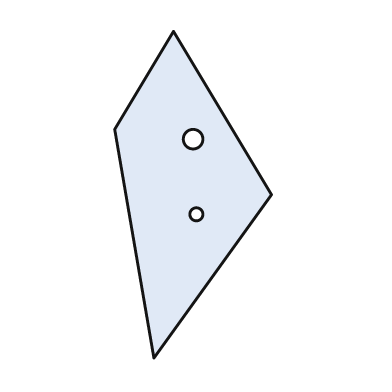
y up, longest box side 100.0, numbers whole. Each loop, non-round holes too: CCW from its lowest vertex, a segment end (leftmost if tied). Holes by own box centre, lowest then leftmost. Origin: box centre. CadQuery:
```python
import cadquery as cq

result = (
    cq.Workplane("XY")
    .moveTo(-12.0, -50.0)
    .lineTo(24.0, 0.0)
    .lineTo(-6.0, 50.0)
    .lineTo(-24.0, 20.0)
    .close()
    .moveTo(1.0, -6.0)
    .circle(2.0)
    .moveTo(0.0, 17.0)
    .circle(3.0)
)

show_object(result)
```